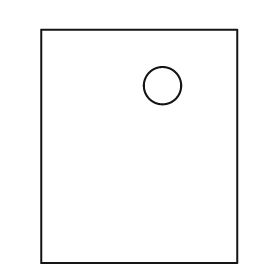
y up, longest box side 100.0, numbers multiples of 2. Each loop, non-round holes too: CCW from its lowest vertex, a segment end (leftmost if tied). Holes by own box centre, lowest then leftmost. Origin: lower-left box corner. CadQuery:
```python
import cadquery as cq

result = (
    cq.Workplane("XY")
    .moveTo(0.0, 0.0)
    .lineTo(84.0, 0.0)
    .lineTo(84.0, 100.0)
    .lineTo(0.0, 100.0)
    .close()
    .moveTo(52.0, 76.0)
    .circle(8.0)
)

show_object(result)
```